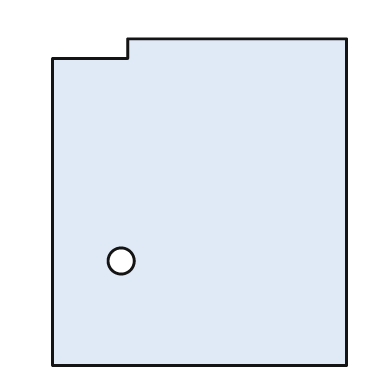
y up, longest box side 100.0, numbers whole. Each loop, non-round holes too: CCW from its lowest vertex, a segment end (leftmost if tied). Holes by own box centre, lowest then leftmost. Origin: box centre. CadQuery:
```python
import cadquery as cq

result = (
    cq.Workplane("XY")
    .moveTo(-45.0, -50.0)
    .lineTo(45.0, -50.0)
    .lineTo(45.0, 50.0)
    .lineTo(-22.0, 50.0)
    .lineTo(-22.0, 44.0)
    .lineTo(-45.0, 44.0)
    .close()
    .moveTo(-24.0, -18.0)
    .circle(4.0)
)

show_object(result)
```